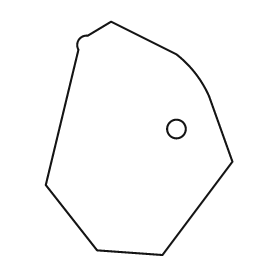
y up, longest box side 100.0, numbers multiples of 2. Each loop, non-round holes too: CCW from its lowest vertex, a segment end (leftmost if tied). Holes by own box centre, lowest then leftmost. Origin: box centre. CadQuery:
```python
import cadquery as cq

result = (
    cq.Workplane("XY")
    .moveTo(10.0, -50.0)
    .lineTo(40.0, -10.0)
    .lineTo(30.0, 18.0)
    .threePointArc((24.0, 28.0), (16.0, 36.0))
    .lineTo(-12.0, 50.0)
    .lineTo(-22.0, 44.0)
    .threePointArc((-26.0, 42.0), (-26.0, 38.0))
    .lineTo(-40.0, -20.0)
    .lineTo(-18.0, -48.0)
    .close()
    .moveTo(16.0, 4.0)
    .circle(4.0)
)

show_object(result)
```